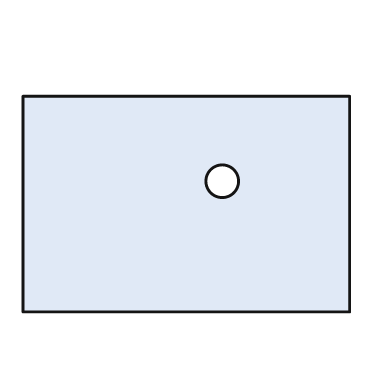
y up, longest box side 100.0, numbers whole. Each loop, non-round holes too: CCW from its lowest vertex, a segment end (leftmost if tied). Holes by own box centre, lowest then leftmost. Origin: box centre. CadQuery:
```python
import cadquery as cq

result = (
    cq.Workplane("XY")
    .moveTo(-50.0, -33.0)
    .lineTo(50.0, -33.0)
    .lineTo(50.0, 33.0)
    .lineTo(-50.0, 33.0)
    .close()
    .moveTo(11.0, 7.0)
    .circle(5.0)
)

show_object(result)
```